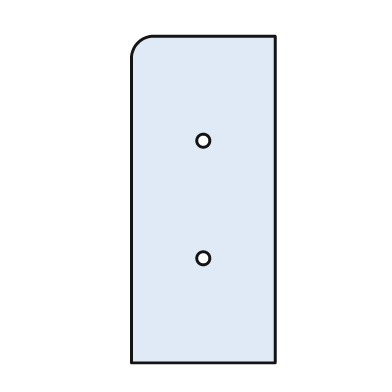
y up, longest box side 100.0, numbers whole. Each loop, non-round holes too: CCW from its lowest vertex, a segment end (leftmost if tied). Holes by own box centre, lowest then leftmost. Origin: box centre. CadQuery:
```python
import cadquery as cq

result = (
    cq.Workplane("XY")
    .moveTo(-22.0, -50.0)
    .lineTo(22.0, -50.0)
    .lineTo(22.0, 50.0)
    .lineTo(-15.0, 50.0)
    .threePointArc((-20.0, 48.0), (-22.0, 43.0))
    .close()
    .moveTo(0.0, -18.0)
    .circle(2.0)
    .moveTo(0.0, 18.0)
    .circle(2.0)
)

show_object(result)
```